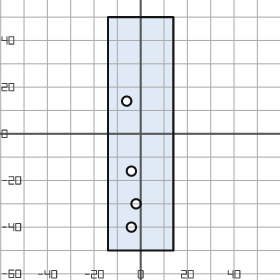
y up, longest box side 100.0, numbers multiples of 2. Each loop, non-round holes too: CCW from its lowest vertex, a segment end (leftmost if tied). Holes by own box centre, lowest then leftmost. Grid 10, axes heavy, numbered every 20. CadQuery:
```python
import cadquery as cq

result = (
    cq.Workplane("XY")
    .moveTo(-14.0, -50.0)
    .lineTo(14.0, -50.0)
    .lineTo(14.0, 50.0)
    .lineTo(-14.0, 50.0)
    .close()
    .moveTo(-4.0, -40.0)
    .circle(2.0)
    .moveTo(-2.0, -30.0)
    .circle(2.0)
    .moveTo(-4.0, -16.0)
    .circle(2.0)
    .moveTo(-6.0, 14.0)
    .circle(2.0)
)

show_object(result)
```